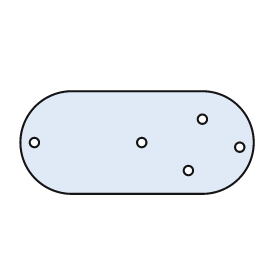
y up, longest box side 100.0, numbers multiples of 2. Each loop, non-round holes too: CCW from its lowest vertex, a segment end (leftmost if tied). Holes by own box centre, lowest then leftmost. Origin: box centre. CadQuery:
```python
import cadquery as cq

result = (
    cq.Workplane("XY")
    .moveTo(-28.0, -22.0)
    .lineTo(28.0, -22.0)
    .threePointArc((50.0, 0.0), (28.0, 22.0))
    .lineTo(-28.0, 22.0)
    .threePointArc((-50.0, 0.0), (-28.0, -22.0))
    .close()
    .moveTo(22.0, -12.0)
    .circle(2.0)
    .moveTo(44.0, -2.0)
    .circle(2.0)
    .moveTo(-44.0, 0.0)
    .circle(2.0)
    .moveTo(2.0, 0.0)
    .circle(2.0)
    .moveTo(28.0, 10.0)
    .circle(2.0)
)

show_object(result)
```